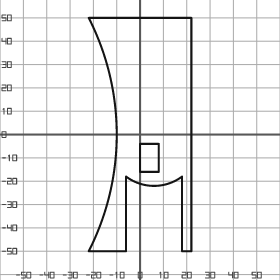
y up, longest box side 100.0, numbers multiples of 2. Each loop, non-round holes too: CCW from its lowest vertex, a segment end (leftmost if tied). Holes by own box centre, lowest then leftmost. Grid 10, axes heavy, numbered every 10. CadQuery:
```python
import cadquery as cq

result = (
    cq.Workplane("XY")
    .moveTo(-22.0, -50.0)
    .lineTo(-6.0, -50.0)
    .lineTo(-6.0, -18.0)
    .threePointArc((6.0, -22.0), (18.0, -18.0))
    .lineTo(18.0, -50.0)
    .lineTo(22.0, -50.0)
    .lineTo(22.0, 50.0)
    .lineTo(-22.0, 50.0)
    .threePointArc((-10.0, 0.0), (-22.0, -50.0))
    .close()
    .moveTo(0.0, -16.0)
    .lineTo(8.0, -16.0)
    .lineTo(8.0, -4.0)
    .lineTo(0.0, -4.0)
    .close()
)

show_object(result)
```